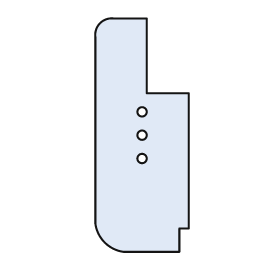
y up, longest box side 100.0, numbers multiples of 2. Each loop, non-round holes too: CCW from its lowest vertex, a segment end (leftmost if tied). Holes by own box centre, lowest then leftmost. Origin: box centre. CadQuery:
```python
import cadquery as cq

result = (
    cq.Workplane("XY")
    .moveTo(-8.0, -50.0)
    .lineTo(16.0, -50.0)
    .lineTo(16.0, -40.0)
    .lineTo(20.0, -40.0)
    .lineTo(20.0, 18.0)
    .lineTo(2.0, 18.0)
    .lineTo(2.0, 50.0)
    .lineTo(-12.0, 50.0)
    .threePointArc((-18.0, 48.0), (-20.0, 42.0))
    .lineTo(-20.0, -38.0)
    .threePointArc((-16.0, -46.0), (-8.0, -50.0))
    .close()
    .moveTo(0.0, -10.0)
    .circle(2.0)
    .moveTo(0.0, 0.0)
    .circle(2.0)
    .moveTo(0.0, 10.0)
    .circle(2.0)
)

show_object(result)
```